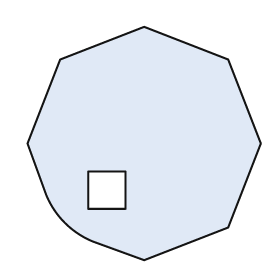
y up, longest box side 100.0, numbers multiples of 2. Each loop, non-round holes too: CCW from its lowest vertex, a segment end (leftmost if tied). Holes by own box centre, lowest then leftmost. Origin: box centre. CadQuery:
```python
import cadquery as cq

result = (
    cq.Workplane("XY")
    .moveTo(0.0, -50.0)
    .lineTo(36.0, -36.0)
    .lineTo(50.0, 0.0)
    .lineTo(36.0, 36.0)
    .lineTo(0.0, 50.0)
    .lineTo(-36.0, 36.0)
    .lineTo(-50.0, 0.0)
    .lineTo(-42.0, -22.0)
    .threePointArc((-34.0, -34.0), (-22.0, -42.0))
    .close()
    .moveTo(-24.0, -28.0)
    .lineTo(-8.0, -28.0)
    .lineTo(-8.0, -12.0)
    .lineTo(-24.0, -12.0)
    .close()
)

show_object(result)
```